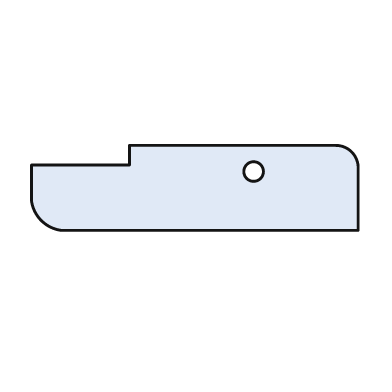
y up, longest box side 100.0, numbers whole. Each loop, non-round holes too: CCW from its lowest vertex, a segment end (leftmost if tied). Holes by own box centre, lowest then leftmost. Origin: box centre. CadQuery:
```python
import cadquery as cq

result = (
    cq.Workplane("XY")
    .moveTo(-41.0, -13.0)
    .lineTo(50.0, -13.0)
    .lineTo(50.0, 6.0)
    .threePointArc((48.0, 11.0), (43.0, 13.0))
    .lineTo(-20.0, 13.0)
    .lineTo(-20.0, 7.0)
    .lineTo(-50.0, 7.0)
    .lineTo(-50.0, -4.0)
    .threePointArc((-47.0, -10.0), (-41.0, -13.0))
    .close()
    .moveTo(18.0, 5.0)
    .circle(3.0)
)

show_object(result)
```